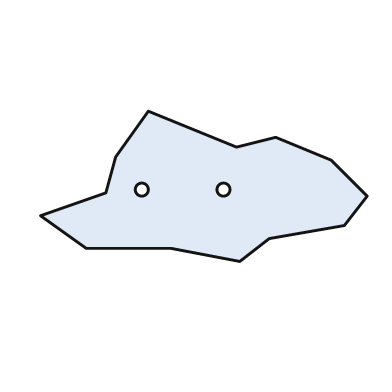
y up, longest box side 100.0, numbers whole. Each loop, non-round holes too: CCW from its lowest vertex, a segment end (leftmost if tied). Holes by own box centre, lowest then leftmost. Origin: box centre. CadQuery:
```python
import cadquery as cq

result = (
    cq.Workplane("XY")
    .moveTo(11.0, -23.0)
    .lineTo(20.0, -16.0)
    .lineTo(43.0, -12.0)
    .lineTo(50.0, -3.0)
    .lineTo(39.0, 8.0)
    .lineTo(22.0, 15.0)
    .lineTo(10.0, 12.0)
    .lineTo(-17.0, 23.0)
    .lineTo(-27.0, 9.0)
    .lineTo(-30.0, -2.0)
    .lineTo(-50.0, -9.0)
    .lineTo(-36.0, -19.0)
    .lineTo(-10.0, -19.0)
    .close()
    .moveTo(-19.0, -1.0)
    .circle(2.0)
    .moveTo(6.0, -1.0)
    .circle(2.0)
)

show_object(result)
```